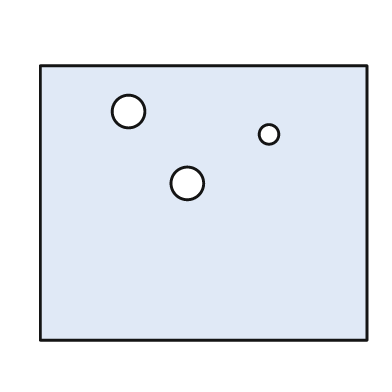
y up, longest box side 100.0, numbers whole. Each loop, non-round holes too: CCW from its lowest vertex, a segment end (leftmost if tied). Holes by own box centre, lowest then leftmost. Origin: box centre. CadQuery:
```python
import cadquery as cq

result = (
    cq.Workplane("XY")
    .moveTo(-50.0, -42.0)
    .lineTo(50.0, -42.0)
    .lineTo(50.0, 42.0)
    .lineTo(-50.0, 42.0)
    .close()
    .moveTo(-5.0, 6.0)
    .circle(5.0)
    .moveTo(20.0, 21.0)
    .circle(3.0)
    .moveTo(-23.0, 28.0)
    .circle(5.0)
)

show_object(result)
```